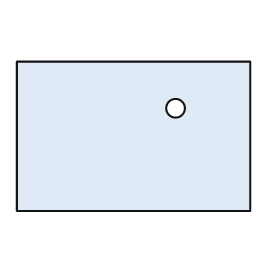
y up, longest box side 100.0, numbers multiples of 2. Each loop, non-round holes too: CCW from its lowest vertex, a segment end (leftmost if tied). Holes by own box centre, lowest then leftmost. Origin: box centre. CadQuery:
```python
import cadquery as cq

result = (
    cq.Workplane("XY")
    .moveTo(-50.0, -32.0)
    .lineTo(50.0, -32.0)
    .lineTo(50.0, 32.0)
    .lineTo(-50.0, 32.0)
    .close()
    .moveTo(18.0, 12.0)
    .circle(4.0)
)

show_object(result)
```